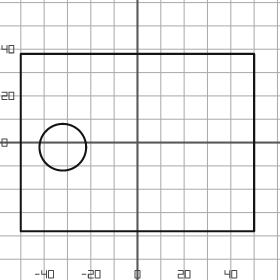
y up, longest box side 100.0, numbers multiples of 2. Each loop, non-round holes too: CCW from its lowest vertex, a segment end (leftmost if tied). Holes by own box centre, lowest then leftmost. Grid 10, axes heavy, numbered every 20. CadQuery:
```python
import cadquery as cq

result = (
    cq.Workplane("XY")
    .moveTo(-50.0, -38.0)
    .lineTo(50.0, -38.0)
    .lineTo(50.0, 38.0)
    .lineTo(-50.0, 38.0)
    .close()
    .moveTo(-32.0, -2.0)
    .circle(10.0)
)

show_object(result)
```